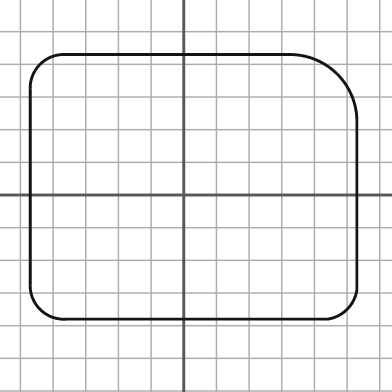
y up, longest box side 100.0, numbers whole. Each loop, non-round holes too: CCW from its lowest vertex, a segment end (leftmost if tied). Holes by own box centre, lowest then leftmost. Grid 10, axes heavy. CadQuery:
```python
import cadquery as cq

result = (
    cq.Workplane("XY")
    .moveTo(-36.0, -38.0)
    .lineTo(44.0, -38.0)
    .threePointArc((50.0, -35.0), (53.0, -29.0))
    .lineTo(53.0, 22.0)
    .threePointArc((47.0, 37.0), (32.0, 43.0))
    .lineTo(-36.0, 43.0)
    .threePointArc((-44.0, 40.0), (-47.0, 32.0))
    .lineTo(-47.0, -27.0)
    .threePointArc((-44.0, -35.0), (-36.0, -38.0))
    .close()
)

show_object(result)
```